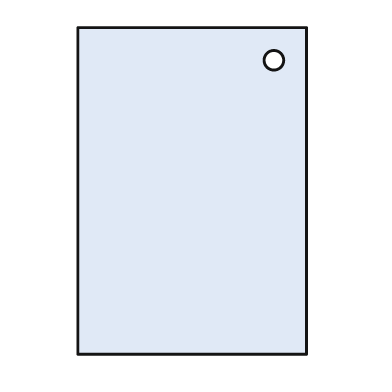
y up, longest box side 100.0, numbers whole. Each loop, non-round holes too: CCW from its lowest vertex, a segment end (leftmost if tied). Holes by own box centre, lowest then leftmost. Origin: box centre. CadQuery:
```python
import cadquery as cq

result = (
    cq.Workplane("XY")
    .moveTo(-35.0, -50.0)
    .lineTo(35.0, -50.0)
    .lineTo(35.0, 50.0)
    .lineTo(-35.0, 50.0)
    .close()
    .moveTo(25.0, 40.0)
    .circle(3.0)
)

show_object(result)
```